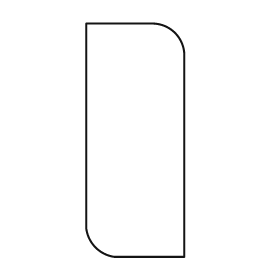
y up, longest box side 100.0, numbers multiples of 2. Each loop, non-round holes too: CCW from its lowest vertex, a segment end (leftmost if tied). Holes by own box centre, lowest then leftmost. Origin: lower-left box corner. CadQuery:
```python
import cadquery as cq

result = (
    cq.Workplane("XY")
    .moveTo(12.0, 0.0)
    .lineTo(42.0, 0.0)
    .lineTo(42.0, 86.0)
    .threePointArc((38.0, 96.0), (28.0, 100.0))
    .lineTo(0.0, 100.0)
    .lineTo(0.0, 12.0)
    .threePointArc((4.0, 4.0), (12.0, 0.0))
    .close()
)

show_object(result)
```